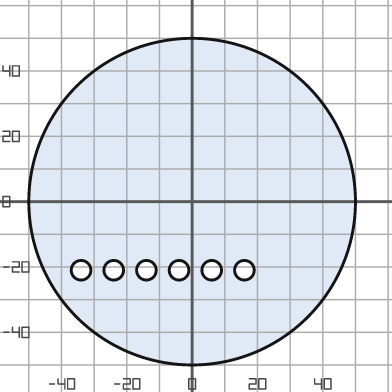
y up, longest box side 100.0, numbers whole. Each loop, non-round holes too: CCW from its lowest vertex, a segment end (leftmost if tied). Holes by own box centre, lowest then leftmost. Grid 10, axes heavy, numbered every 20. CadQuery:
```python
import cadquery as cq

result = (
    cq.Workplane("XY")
    .moveTo(0.0, 0.0)
    .circle(50.0)
    .moveTo(-34.0, -21.0)
    .circle(3.0)
    .moveTo(-24.0, -21.0)
    .circle(3.0)
    .moveTo(-14.0, -21.0)
    .circle(3.0)
    .moveTo(-4.0, -21.0)
    .circle(3.0)
    .moveTo(6.0, -21.0)
    .circle(3.0)
    .moveTo(16.0, -21.0)
    .circle(3.0)
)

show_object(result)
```